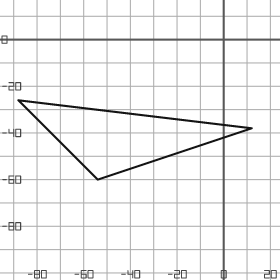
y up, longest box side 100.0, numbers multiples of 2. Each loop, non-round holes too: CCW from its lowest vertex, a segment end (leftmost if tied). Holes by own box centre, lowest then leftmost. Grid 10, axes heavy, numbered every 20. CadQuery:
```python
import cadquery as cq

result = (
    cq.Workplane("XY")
    .moveTo(-54.0, -60.0)
    .lineTo(12.0, -38.0)
    .lineTo(-88.0, -26.0)
    .close()
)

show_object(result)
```